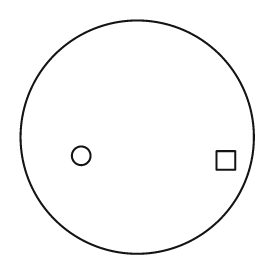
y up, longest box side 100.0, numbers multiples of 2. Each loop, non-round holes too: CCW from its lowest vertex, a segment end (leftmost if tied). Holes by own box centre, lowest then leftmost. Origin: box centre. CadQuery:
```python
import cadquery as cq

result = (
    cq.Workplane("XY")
    .moveTo(0.0, 0.0)
    .circle(50.0)
    .moveTo(34.0, -14.0)
    .lineTo(42.0, -14.0)
    .lineTo(42.0, -6.0)
    .lineTo(34.0, -6.0)
    .close()
    .moveTo(-24.0, -8.0)
    .circle(4.0)
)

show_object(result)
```